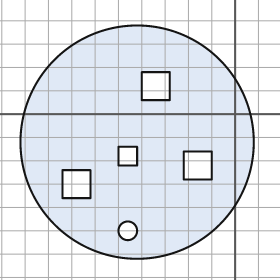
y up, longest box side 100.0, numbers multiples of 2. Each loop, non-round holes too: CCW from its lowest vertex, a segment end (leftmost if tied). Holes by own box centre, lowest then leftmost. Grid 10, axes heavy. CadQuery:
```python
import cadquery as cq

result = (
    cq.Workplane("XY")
    .moveTo(-42.0, -12.0)
    .circle(50.0)
    .moveTo(-46.0, -50.0)
    .circle(4.0)
    .moveTo(-74.0, -36.0)
    .lineTo(-62.0, -36.0)
    .lineTo(-62.0, -24.0)
    .lineTo(-74.0, -24.0)
    .close()
    .moveTo(-22.0, -28.0)
    .lineTo(-10.0, -28.0)
    .lineTo(-10.0, -16.0)
    .lineTo(-22.0, -16.0)
    .close()
    .moveTo(-50.0, -22.0)
    .lineTo(-42.0, -22.0)
    .lineTo(-42.0, -14.0)
    .lineTo(-50.0, -14.0)
    .close()
    .moveTo(-40.0, 6.0)
    .lineTo(-28.0, 6.0)
    .lineTo(-28.0, 18.0)
    .lineTo(-40.0, 18.0)
    .close()
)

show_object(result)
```